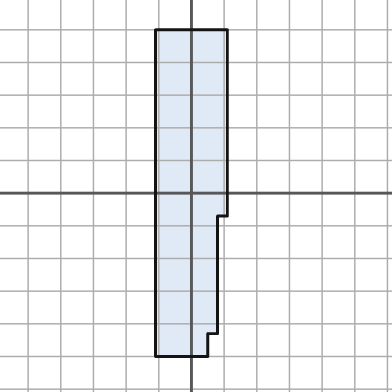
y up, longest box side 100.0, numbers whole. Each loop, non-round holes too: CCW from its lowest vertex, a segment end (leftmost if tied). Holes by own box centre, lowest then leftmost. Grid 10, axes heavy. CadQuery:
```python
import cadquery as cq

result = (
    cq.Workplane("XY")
    .moveTo(-11.0, -50.0)
    .lineTo(5.0, -50.0)
    .lineTo(5.0, -43.0)
    .lineTo(8.0, -43.0)
    .lineTo(8.0, -7.0)
    .lineTo(11.0, -7.0)
    .lineTo(11.0, 50.0)
    .lineTo(-11.0, 50.0)
    .close()
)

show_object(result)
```